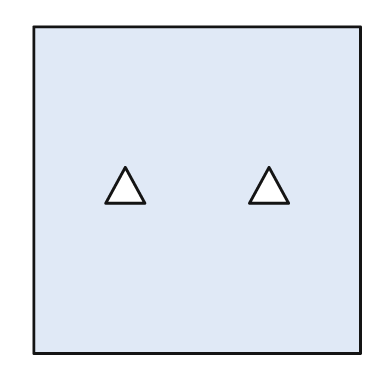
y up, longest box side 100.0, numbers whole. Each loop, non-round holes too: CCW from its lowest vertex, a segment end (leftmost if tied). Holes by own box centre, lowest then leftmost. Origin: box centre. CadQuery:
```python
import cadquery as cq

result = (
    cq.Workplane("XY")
    .moveTo(-50.0, -50.0)
    .lineTo(50.0, -50.0)
    .lineTo(50.0, 50.0)
    .lineTo(-50.0, 50.0)
    .close()
    .moveTo(-28.0, -4.0)
    .lineTo(-16.0, -4.0)
    .lineTo(-22.0, 7.0)
    .close()
    .moveTo(16.0, -4.0)
    .lineTo(28.0, -4.0)
    .lineTo(22.0, 7.0)
    .close()
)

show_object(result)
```